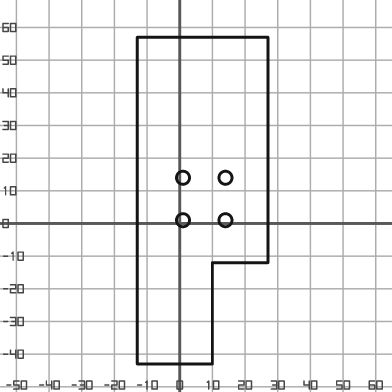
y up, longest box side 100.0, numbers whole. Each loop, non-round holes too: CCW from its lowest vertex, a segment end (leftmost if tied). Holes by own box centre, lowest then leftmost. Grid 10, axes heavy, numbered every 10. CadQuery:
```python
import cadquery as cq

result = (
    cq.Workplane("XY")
    .moveTo(-13.0, -43.0)
    .lineTo(10.0, -43.0)
    .lineTo(10.0, -12.0)
    .lineTo(27.0, -12.0)
    .lineTo(27.0, 57.0)
    .lineTo(-13.0, 57.0)
    .close()
    .moveTo(1.0, 1.0)
    .circle(2.0)
    .moveTo(14.0, 1.0)
    .circle(2.0)
    .moveTo(1.0, 14.0)
    .circle(2.0)
    .moveTo(14.0, 14.0)
    .circle(2.0)
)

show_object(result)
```